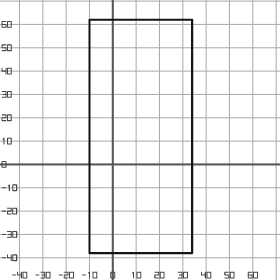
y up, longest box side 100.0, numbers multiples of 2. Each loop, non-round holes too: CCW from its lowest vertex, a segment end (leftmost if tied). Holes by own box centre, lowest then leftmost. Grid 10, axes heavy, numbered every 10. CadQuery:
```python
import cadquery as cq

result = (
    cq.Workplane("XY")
    .moveTo(-10.0, -38.0)
    .lineTo(34.0, -38.0)
    .lineTo(34.0, 62.0)
    .lineTo(-10.0, 62.0)
    .close()
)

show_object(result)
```